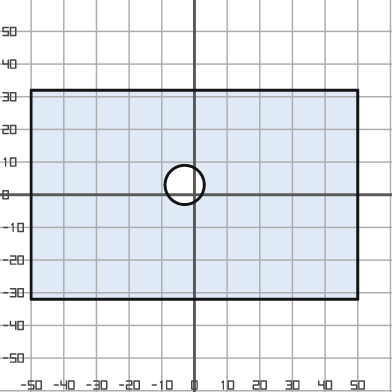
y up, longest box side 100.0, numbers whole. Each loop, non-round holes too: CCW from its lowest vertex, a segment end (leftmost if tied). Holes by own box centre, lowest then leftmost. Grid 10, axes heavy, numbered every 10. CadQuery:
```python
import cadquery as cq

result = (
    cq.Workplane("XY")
    .moveTo(-50.0, -32.0)
    .lineTo(50.0, -32.0)
    .lineTo(50.0, 32.0)
    .lineTo(-50.0, 32.0)
    .close()
    .moveTo(-3.0, 3.0)
    .circle(6.0)
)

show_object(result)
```